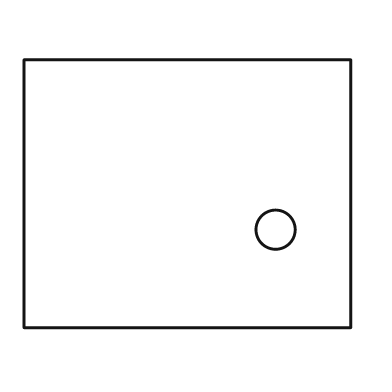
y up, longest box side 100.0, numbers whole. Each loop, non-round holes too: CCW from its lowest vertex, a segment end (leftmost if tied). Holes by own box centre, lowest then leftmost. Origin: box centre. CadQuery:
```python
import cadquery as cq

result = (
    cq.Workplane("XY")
    .moveTo(-50.0, -41.0)
    .lineTo(50.0, -41.0)
    .lineTo(50.0, 41.0)
    .lineTo(-50.0, 41.0)
    .close()
    .moveTo(27.0, -11.0)
    .circle(6.0)
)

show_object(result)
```